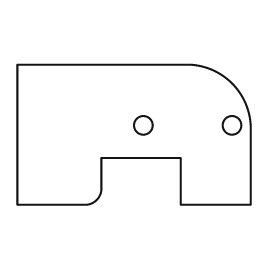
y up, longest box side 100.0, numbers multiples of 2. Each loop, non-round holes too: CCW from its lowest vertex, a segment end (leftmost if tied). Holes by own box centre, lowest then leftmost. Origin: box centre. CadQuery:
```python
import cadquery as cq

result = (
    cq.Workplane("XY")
    .moveTo(-50.0, -30.0)
    .lineTo(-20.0, -30.0)
    .threePointArc((-16.0, -28.0), (-14.0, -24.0))
    .lineTo(-14.0, -10.0)
    .lineTo(20.0, -10.0)
    .lineTo(20.0, -30.0)
    .lineTo(50.0, -30.0)
    .lineTo(50.0, 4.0)
    .threePointArc((42.0, 22.0), (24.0, 30.0))
    .lineTo(-50.0, 30.0)
    .close()
    .moveTo(4.0, 4.0)
    .circle(4.0)
    .moveTo(42.0, 4.0)
    .circle(4.0)
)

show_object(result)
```